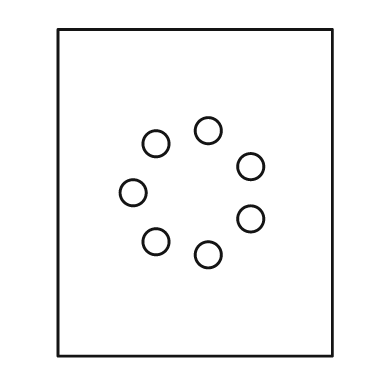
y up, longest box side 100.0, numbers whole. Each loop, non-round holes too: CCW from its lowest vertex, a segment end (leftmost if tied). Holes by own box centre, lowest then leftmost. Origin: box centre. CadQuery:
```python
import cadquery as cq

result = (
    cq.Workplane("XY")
    .moveTo(-42.0, -50.0)
    .lineTo(42.0, -50.0)
    .lineTo(42.0, 50.0)
    .lineTo(-42.0, 50.0)
    .close()
    .moveTo(4.0, -19.0)
    .circle(4.0)
    .moveTo(-12.0, -15.0)
    .circle(4.0)
    .moveTo(17.0, -8.0)
    .circle(4.0)
    .moveTo(-19.0, 0.0)
    .circle(4.0)
    .moveTo(17.0, 8.0)
    .circle(4.0)
    .moveTo(-12.0, 15.0)
    .circle(4.0)
    .moveTo(4.0, 19.0)
    .circle(4.0)
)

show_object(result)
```